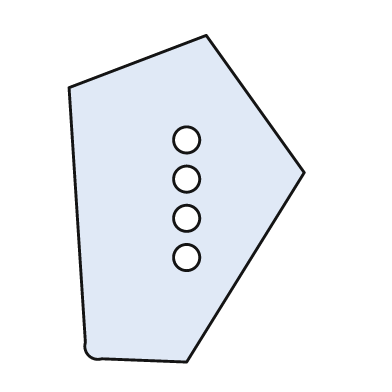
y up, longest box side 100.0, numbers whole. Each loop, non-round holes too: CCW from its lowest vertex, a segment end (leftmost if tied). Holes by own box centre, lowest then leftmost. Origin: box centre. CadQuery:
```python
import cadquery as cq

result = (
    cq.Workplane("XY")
    .moveTo(0.0, -50.0)
    .lineTo(36.0, 8.0)
    .lineTo(6.0, 50.0)
    .lineTo(-36.0, 34.0)
    .lineTo(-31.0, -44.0)
    .threePointArc((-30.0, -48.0), (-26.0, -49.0))
    .close()
    .moveTo(0.0, -18.0)
    .circle(4.0)
    .moveTo(0.0, -6.0)
    .circle(4.0)
    .moveTo(0.0, 6.0)
    .circle(4.0)
    .moveTo(0.0, 18.0)
    .circle(4.0)
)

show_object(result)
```